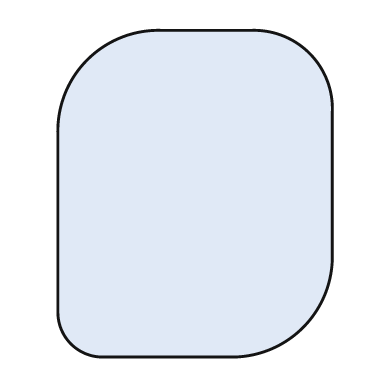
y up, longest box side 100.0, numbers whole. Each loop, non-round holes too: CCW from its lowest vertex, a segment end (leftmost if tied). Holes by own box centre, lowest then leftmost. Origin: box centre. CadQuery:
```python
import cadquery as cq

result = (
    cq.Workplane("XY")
    .moveTo(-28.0, -50.0)
    .lineTo(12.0, -50.0)
    .threePointArc((33.0, -41.0), (42.0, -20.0))
    .lineTo(42.0, 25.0)
    .threePointArc((35.0, 43.0), (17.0, 50.0))
    .lineTo(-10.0, 50.0)
    .threePointArc((-33.0, 41.0), (-42.0, 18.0))
    .lineTo(-42.0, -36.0)
    .threePointArc((-38.0, -46.0), (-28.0, -50.0))
    .close()
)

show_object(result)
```